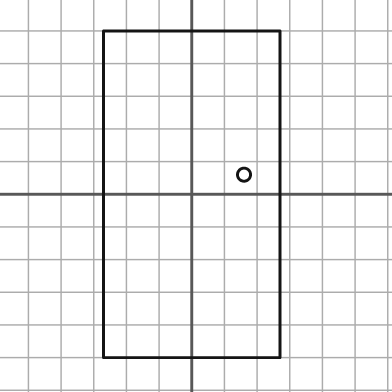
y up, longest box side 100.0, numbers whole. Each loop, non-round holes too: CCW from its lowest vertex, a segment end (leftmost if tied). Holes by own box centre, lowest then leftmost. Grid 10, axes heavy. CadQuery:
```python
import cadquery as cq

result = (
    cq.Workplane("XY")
    .moveTo(-27.0, -50.0)
    .lineTo(27.0, -50.0)
    .lineTo(27.0, 50.0)
    .lineTo(-27.0, 50.0)
    .close()
    .moveTo(16.0, 6.0)
    .circle(2.0)
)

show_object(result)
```